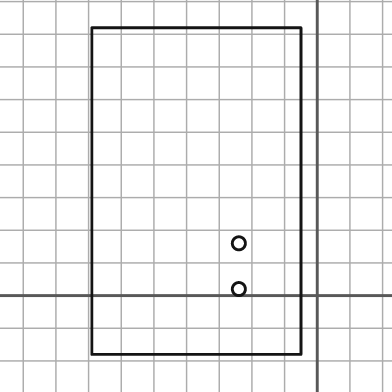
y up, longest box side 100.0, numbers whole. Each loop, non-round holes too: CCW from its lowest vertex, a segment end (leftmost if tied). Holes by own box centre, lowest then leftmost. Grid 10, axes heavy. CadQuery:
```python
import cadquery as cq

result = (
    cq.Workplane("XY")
    .moveTo(-69.0, -18.0)
    .lineTo(-5.0, -18.0)
    .lineTo(-5.0, 82.0)
    .lineTo(-69.0, 82.0)
    .close()
    .moveTo(-24.0, 2.0)
    .circle(2.0)
    .moveTo(-24.0, 16.0)
    .circle(2.0)
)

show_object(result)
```